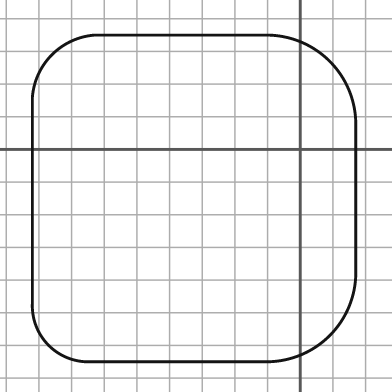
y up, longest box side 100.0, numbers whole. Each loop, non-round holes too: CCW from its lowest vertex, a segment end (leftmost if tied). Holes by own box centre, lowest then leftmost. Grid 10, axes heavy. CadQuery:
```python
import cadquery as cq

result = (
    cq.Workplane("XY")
    .moveTo(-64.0, -65.0)
    .lineTo(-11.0, -65.0)
    .threePointArc((9.0, -57.0), (17.0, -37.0))
    .lineTo(17.0, 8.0)
    .threePointArc((9.0, 27.0), (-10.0, 35.0))
    .lineTo(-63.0, 35.0)
    .threePointArc((-76.0, 29.0), (-82.0, 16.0))
    .lineTo(-82.0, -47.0)
    .threePointArc((-77.0, -60.0), (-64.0, -65.0))
    .close()
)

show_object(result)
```